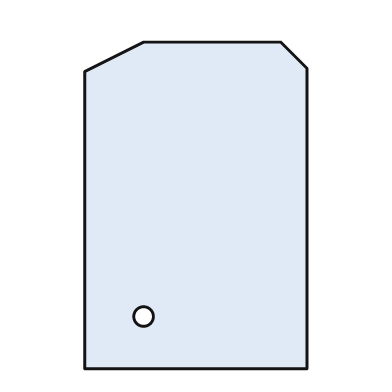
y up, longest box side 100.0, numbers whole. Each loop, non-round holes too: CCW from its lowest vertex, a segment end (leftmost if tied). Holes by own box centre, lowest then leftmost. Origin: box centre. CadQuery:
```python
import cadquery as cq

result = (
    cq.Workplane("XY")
    .moveTo(-34.0, -50.0)
    .lineTo(34.0, -50.0)
    .lineTo(34.0, 42.0)
    .lineTo(26.0, 50.0)
    .lineTo(-16.0, 50.0)
    .lineTo(-34.0, 41.0)
    .close()
    .moveTo(-16.0, -34.0)
    .circle(3.0)
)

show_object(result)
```